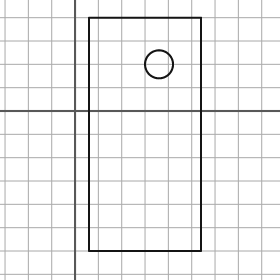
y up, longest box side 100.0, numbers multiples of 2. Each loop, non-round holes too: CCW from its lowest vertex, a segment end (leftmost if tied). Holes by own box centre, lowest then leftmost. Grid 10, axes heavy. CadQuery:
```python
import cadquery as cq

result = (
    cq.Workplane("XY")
    .moveTo(6.0, -60.0)
    .lineTo(54.0, -60.0)
    .lineTo(54.0, 40.0)
    .lineTo(6.0, 40.0)
    .close()
    .moveTo(36.0, 20.0)
    .circle(6.0)
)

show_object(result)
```